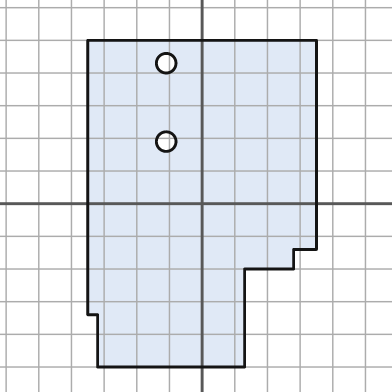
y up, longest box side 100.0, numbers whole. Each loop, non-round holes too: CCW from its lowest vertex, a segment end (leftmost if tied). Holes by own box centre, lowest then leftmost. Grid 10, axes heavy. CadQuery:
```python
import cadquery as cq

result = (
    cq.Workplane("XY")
    .moveTo(-32.0, -50.0)
    .lineTo(13.0, -50.0)
    .lineTo(13.0, -20.0)
    .lineTo(28.0, -20.0)
    .lineTo(28.0, -14.0)
    .lineTo(35.0, -14.0)
    .lineTo(35.0, 50.0)
    .lineTo(-35.0, 50.0)
    .lineTo(-35.0, -34.0)
    .lineTo(-32.0, -34.0)
    .close()
    .moveTo(-11.0, 19.0)
    .circle(3.0)
    .moveTo(-11.0, 43.0)
    .circle(3.0)
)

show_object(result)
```